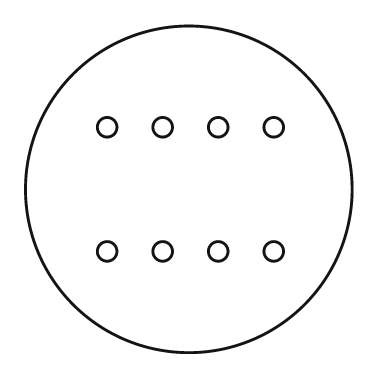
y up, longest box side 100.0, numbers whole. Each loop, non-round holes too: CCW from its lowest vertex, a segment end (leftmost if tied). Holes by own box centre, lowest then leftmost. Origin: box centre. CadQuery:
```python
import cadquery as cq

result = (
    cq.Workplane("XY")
    .moveTo(0.0, 0.0)
    .circle(50.0)
    .moveTo(-25.0, -19.0)
    .circle(3.0)
    .moveTo(-8.0, -19.0)
    .circle(3.0)
    .moveTo(9.0, -19.0)
    .circle(3.0)
    .moveTo(26.0, -19.0)
    .circle(3.0)
    .moveTo(-25.0, 19.0)
    .circle(3.0)
    .moveTo(-8.0, 19.0)
    .circle(3.0)
    .moveTo(9.0, 19.0)
    .circle(3.0)
    .moveTo(26.0, 19.0)
    .circle(3.0)
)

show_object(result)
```